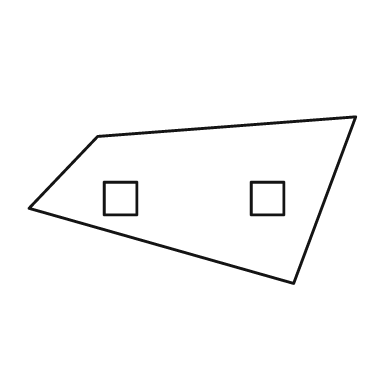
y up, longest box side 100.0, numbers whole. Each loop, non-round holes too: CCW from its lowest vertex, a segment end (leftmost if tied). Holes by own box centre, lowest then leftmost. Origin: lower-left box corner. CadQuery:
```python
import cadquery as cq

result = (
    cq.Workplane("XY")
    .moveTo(81.0, 0.0)
    .lineTo(100.0, 51.0)
    .lineTo(21.0, 45.0)
    .lineTo(0.0, 23.0)
    .close()
    .moveTo(23.0, 21.0)
    .lineTo(33.0, 21.0)
    .lineTo(33.0, 31.0)
    .lineTo(23.0, 31.0)
    .close()
    .moveTo(68.0, 21.0)
    .lineTo(78.0, 21.0)
    .lineTo(78.0, 31.0)
    .lineTo(68.0, 31.0)
    .close()
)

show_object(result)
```